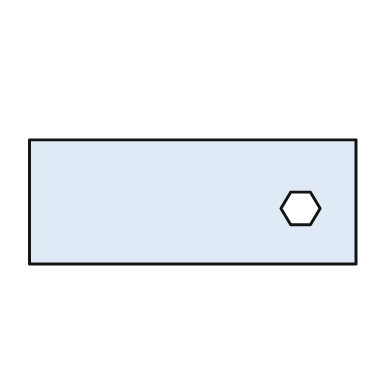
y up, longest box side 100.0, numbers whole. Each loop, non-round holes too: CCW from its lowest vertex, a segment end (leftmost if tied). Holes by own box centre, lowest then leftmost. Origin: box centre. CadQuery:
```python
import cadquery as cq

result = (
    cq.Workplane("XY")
    .moveTo(-50.0, -19.0)
    .lineTo(50.0, -19.0)
    .lineTo(50.0, 19.0)
    .lineTo(-50.0, 19.0)
    .close()
    .moveTo(30.0, -7.0)
    .lineTo(36.0, -7.0)
    .lineTo(39.0, -2.0)
    .lineTo(36.0, 3.0)
    .lineTo(30.0, 3.0)
    .lineTo(27.0, -2.0)
    .close()
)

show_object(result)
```